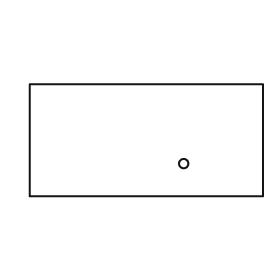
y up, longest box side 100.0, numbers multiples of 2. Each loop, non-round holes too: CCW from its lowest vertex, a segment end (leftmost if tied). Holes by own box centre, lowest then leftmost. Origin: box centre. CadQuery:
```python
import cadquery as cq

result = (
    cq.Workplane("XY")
    .moveTo(-50.0, -24.0)
    .lineTo(50.0, -24.0)
    .lineTo(50.0, 24.0)
    .lineTo(-50.0, 24.0)
    .close()
    .moveTo(16.0, -10.0)
    .circle(2.0)
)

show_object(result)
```